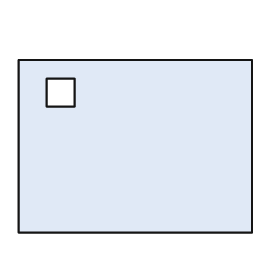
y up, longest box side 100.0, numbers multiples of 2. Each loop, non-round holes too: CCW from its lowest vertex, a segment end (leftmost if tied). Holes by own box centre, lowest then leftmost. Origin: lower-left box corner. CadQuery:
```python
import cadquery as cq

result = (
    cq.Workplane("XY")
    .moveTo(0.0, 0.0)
    .lineTo(100.0, 0.0)
    .lineTo(100.0, 74.0)
    .lineTo(0.0, 74.0)
    .close()
    .moveTo(12.0, 54.0)
    .lineTo(24.0, 54.0)
    .lineTo(24.0, 66.0)
    .lineTo(12.0, 66.0)
    .close()
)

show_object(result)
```